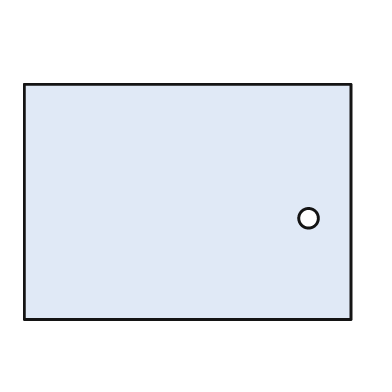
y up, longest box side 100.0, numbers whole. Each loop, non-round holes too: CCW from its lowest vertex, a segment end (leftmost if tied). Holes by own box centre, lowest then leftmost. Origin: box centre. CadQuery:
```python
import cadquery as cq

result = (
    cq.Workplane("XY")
    .moveTo(-50.0, -36.0)
    .lineTo(50.0, -36.0)
    .lineTo(50.0, 36.0)
    .lineTo(-50.0, 36.0)
    .close()
    .moveTo(37.0, -5.0)
    .circle(3.0)
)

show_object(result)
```